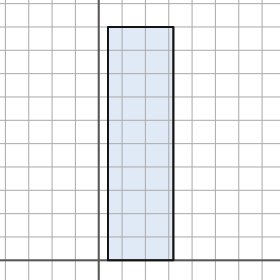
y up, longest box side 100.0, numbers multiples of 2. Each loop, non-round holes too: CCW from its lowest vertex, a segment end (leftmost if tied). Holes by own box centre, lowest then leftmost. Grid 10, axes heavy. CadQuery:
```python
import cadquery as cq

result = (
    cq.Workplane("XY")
    .moveTo(4.0, 0.0)
    .lineTo(32.0, 0.0)
    .lineTo(32.0, 100.0)
    .lineTo(4.0, 100.0)
    .close()
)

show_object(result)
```